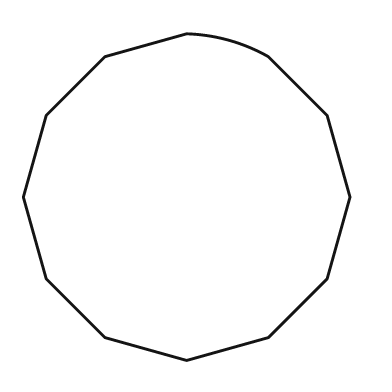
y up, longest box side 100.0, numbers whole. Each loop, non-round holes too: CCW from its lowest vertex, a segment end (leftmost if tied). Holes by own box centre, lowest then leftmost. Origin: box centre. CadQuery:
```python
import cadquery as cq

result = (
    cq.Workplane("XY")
    .moveTo(0.0, -50.0)
    .lineTo(25.0, -43.0)
    .lineTo(43.0, -25.0)
    .lineTo(50.0, 0.0)
    .lineTo(43.0, 25.0)
    .lineTo(25.0, 43.0)
    .threePointArc((13.0, 48.0), (0.0, 50.0))
    .lineTo(-25.0, 43.0)
    .lineTo(-43.0, 25.0)
    .lineTo(-50.0, 0.0)
    .lineTo(-43.0, -25.0)
    .lineTo(-25.0, -43.0)
    .close()
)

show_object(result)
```